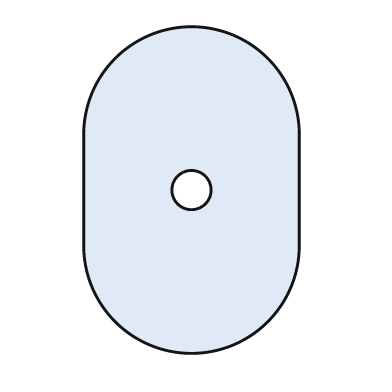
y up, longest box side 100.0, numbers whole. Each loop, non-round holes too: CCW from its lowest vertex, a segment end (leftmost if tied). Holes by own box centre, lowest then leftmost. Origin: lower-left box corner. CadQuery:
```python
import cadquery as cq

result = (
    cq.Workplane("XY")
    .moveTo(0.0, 33.0)
    .threePointArc((33.0, 0.0), (66.0, 33.0))
    .lineTo(66.0, 67.0)
    .threePointArc((33.0, 100.0), (0.0, 67.0))
    .close()
    .moveTo(33.0, 50.0)
    .circle(6.0)
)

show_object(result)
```